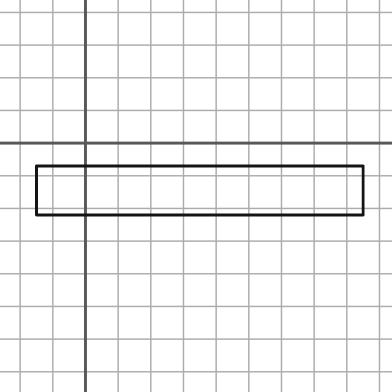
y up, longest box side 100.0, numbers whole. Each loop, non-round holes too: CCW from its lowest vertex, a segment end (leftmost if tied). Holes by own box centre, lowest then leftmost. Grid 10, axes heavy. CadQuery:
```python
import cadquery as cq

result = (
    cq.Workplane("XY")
    .moveTo(-15.0, -22.0)
    .lineTo(85.0, -22.0)
    .lineTo(85.0, -7.0)
    .lineTo(-15.0, -7.0)
    .close()
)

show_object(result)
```